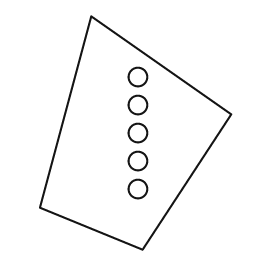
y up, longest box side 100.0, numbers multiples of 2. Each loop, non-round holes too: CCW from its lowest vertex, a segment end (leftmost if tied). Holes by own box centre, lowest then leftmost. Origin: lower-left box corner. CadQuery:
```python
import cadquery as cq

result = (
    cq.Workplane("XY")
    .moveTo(44.0, 0.0)
    .lineTo(82.0, 58.0)
    .lineTo(22.0, 100.0)
    .lineTo(0.0, 18.0)
    .close()
    .moveTo(42.0, 26.0)
    .circle(4.0)
    .moveTo(42.0, 38.0)
    .circle(4.0)
    .moveTo(42.0, 50.0)
    .circle(4.0)
    .moveTo(42.0, 62.0)
    .circle(4.0)
    .moveTo(42.0, 74.0)
    .circle(4.0)
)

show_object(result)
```